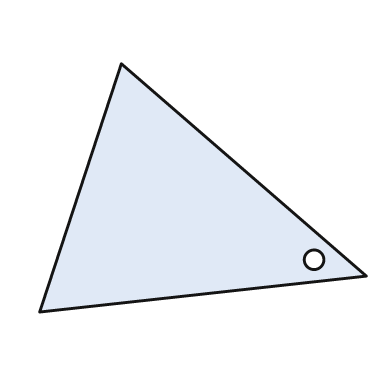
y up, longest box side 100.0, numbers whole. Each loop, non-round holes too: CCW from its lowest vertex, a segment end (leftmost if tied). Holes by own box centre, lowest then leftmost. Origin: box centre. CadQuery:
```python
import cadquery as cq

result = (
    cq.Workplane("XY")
    .moveTo(-50.0, -38.0)
    .lineTo(50.0, -27.0)
    .lineTo(-25.0, 38.0)
    .close()
    .moveTo(34.0, -22.0)
    .circle(3.0)
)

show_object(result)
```